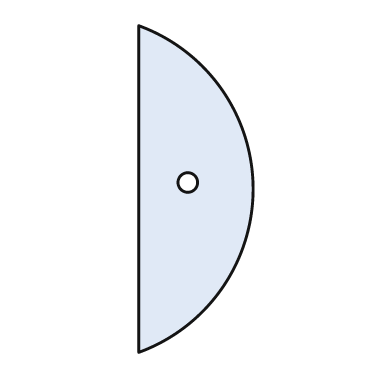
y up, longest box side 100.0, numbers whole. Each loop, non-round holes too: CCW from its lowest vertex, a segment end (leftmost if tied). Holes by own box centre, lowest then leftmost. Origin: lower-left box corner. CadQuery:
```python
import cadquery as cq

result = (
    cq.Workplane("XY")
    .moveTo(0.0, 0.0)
    .threePointArc((35.0, 50.0), (0.0, 100.0))
    .close()
    .moveTo(15.0, 52.0)
    .circle(3.0)
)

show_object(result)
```